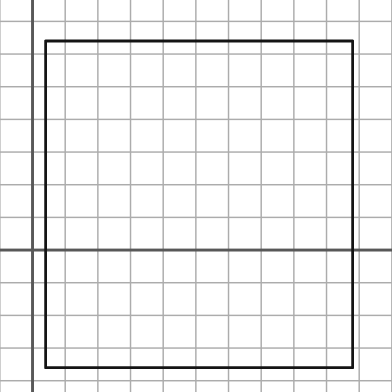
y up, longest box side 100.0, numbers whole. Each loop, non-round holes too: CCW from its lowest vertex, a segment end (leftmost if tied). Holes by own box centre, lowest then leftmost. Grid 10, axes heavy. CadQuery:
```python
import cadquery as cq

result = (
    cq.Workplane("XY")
    .moveTo(4.0, -36.0)
    .lineTo(98.0, -36.0)
    .lineTo(98.0, 64.0)
    .lineTo(4.0, 64.0)
    .close()
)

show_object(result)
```